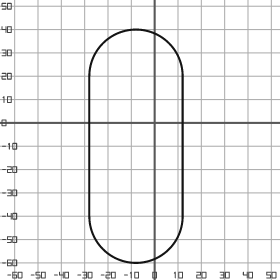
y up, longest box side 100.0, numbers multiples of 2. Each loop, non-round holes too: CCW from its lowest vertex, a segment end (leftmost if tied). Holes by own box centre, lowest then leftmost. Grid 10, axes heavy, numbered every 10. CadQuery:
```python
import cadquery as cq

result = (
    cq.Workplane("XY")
    .moveTo(-28.0, -40.0)
    .threePointArc((-8.0, -60.0), (12.0, -40.0))
    .lineTo(12.0, 20.0)
    .threePointArc((-8.0, 40.0), (-28.0, 20.0))
    .close()
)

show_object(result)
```